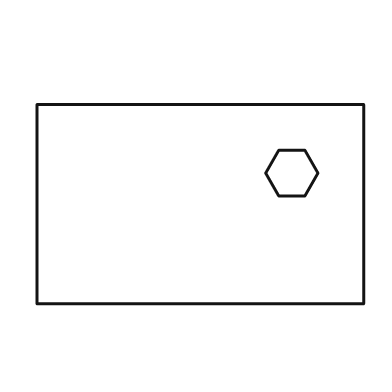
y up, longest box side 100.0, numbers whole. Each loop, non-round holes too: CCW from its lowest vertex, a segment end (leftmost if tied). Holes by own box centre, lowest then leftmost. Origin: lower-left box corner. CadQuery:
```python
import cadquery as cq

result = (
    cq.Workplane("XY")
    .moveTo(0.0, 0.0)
    .lineTo(100.0, 0.0)
    .lineTo(100.0, 61.0)
    .lineTo(0.0, 61.0)
    .close()
    .moveTo(74.0, 33.0)
    .lineTo(82.0, 33.0)
    .lineTo(86.0, 40.0)
    .lineTo(82.0, 47.0)
    .lineTo(74.0, 47.0)
    .lineTo(70.0, 40.0)
    .close()
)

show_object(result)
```